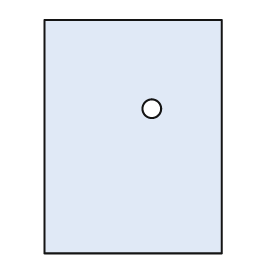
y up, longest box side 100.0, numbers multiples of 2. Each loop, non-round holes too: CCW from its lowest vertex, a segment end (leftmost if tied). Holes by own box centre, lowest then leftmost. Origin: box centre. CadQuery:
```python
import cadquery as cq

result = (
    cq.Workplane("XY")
    .moveTo(-38.0, -50.0)
    .lineTo(38.0, -50.0)
    .lineTo(38.0, 50.0)
    .lineTo(-38.0, 50.0)
    .close()
    .moveTo(8.0, 12.0)
    .circle(4.0)
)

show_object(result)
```